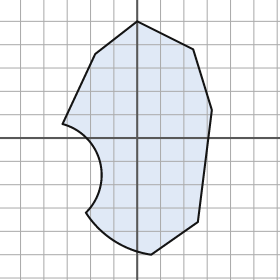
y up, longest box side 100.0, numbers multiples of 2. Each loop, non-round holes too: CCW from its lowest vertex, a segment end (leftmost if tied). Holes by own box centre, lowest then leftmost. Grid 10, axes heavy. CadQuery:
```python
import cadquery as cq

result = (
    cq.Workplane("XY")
    .moveTo(6.0, -50.0)
    .lineTo(26.0, -36.0)
    .lineTo(32.0, 12.0)
    .lineTo(24.0, 38.0)
    .lineTo(0.0, 50.0)
    .lineTo(-18.0, 36.0)
    .lineTo(-32.0, 6.0)
    .threePointArc((-16.0, -10.0), (-22.0, -32.0))
    .threePointArc((-10.0, -44.0), (6.0, -50.0))
    .close()
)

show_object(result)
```